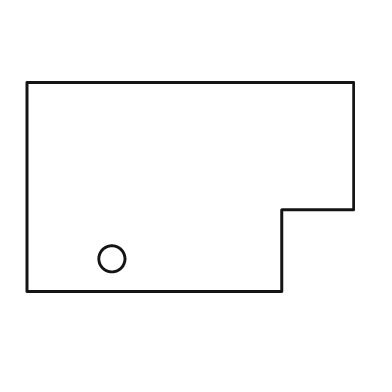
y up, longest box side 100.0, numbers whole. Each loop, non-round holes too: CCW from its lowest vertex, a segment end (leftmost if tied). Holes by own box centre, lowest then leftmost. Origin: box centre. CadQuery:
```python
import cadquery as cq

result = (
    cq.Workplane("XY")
    .moveTo(-50.0, -32.0)
    .lineTo(28.0, -32.0)
    .lineTo(28.0, -7.0)
    .lineTo(50.0, -7.0)
    .lineTo(50.0, 32.0)
    .lineTo(-50.0, 32.0)
    .close()
    .moveTo(-24.0, -22.0)
    .circle(4.0)
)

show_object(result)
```